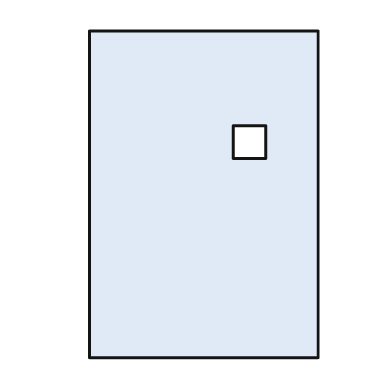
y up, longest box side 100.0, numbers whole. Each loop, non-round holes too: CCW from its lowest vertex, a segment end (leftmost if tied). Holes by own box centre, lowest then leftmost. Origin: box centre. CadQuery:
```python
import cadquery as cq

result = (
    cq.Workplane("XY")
    .moveTo(-35.0, -50.0)
    .lineTo(35.0, -50.0)
    .lineTo(35.0, 50.0)
    .lineTo(-35.0, 50.0)
    .close()
    .moveTo(9.0, 11.0)
    .lineTo(19.0, 11.0)
    .lineTo(19.0, 21.0)
    .lineTo(9.0, 21.0)
    .close()
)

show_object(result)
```